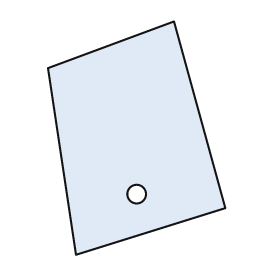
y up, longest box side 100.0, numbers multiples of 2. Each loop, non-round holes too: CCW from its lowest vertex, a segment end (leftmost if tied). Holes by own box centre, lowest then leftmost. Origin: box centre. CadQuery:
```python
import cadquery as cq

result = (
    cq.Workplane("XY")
    .moveTo(-26.0, -50.0)
    .lineTo(38.0, -30.0)
    .lineTo(16.0, 50.0)
    .lineTo(-38.0, 30.0)
    .close()
    .moveTo(0.0, -24.0)
    .circle(4.0)
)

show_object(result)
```